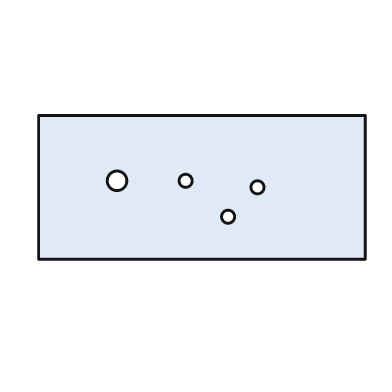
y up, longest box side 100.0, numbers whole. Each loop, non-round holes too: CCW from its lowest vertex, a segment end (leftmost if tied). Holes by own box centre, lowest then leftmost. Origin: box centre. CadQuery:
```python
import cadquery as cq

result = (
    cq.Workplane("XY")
    .moveTo(-50.0, -22.0)
    .lineTo(50.0, -22.0)
    .lineTo(50.0, 22.0)
    .lineTo(-50.0, 22.0)
    .close()
    .moveTo(8.0, -9.0)
    .circle(2.0)
    .moveTo(17.0, 0.0)
    .circle(2.0)
    .moveTo(-26.0, 2.0)
    .circle(3.0)
    .moveTo(-5.0, 2.0)
    .circle(2.0)
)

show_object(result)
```